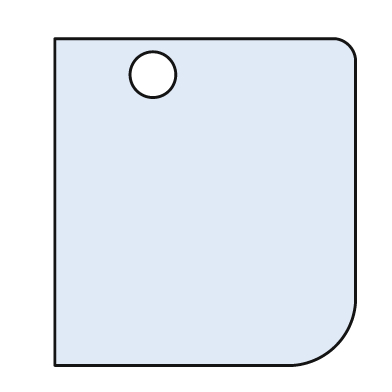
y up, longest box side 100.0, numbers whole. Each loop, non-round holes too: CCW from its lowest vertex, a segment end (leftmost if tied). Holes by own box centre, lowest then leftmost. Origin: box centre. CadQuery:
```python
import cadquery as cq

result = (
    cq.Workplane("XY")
    .moveTo(-46.0, -50.0)
    .lineTo(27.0, -50.0)
    .threePointArc((40.0, -44.0), (46.0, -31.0))
    .lineTo(46.0, 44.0)
    .threePointArc((44.0, 48.0), (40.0, 50.0))
    .lineTo(-46.0, 50.0)
    .close()
    .moveTo(-16.0, 39.0)
    .circle(7.0)
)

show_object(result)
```